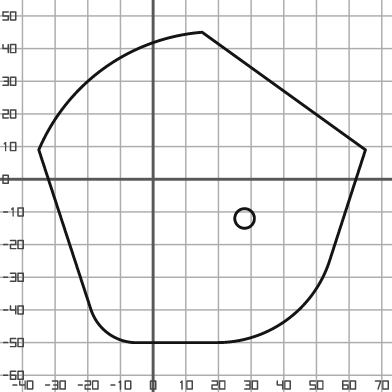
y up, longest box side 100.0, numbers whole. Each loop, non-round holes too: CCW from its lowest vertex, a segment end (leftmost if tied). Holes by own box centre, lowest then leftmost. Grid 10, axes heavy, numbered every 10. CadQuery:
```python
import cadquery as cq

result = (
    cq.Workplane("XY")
    .moveTo(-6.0, -50.0)
    .lineTo(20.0, -50.0)
    .threePointArc((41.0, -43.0), (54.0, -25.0))
    .lineTo(65.0, 9.0)
    .lineTo(15.0, 45.0)
    .threePointArc((-15.0, 34.0), (-35.0, 9.0))
    .lineTo(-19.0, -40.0)
    .threePointArc((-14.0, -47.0), (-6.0, -50.0))
    .close()
    .moveTo(28.0, -12.0)
    .circle(3.0)
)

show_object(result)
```